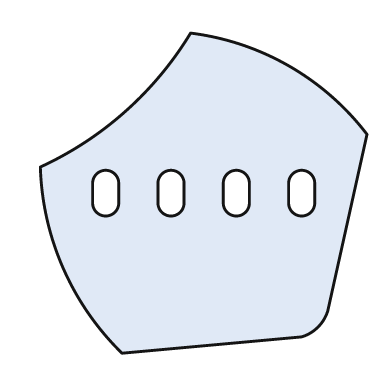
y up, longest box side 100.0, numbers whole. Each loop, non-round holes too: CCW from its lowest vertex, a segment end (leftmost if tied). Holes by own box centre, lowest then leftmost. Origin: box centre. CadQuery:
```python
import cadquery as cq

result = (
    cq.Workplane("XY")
    .moveTo(-25.0, -49.0)
    .lineTo(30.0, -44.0)
    .threePointArc((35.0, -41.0), (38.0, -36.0))
    .lineTo(50.0, 18.0)
    .threePointArc((26.0, 39.0), (-4.0, 49.0))
    .threePointArc((-24.0, 25.0), (-50.0, 8.0))
    .threePointArc((-43.0, -23.0), (-25.0, -49.0))
    .close()
    .moveTo(-34.0, -3.0)
    .threePointArc((-30.0, -7.0), (-26.0, -3.0))
    .lineTo(-26.0, 3.0)
    .threePointArc((-30.0, 7.0), (-34.0, 3.0))
    .close()
    .moveTo(-14.0, -3.0)
    .threePointArc((-10.0, -7.0), (-6.0, -3.0))
    .lineTo(-6.0, 3.0)
    .threePointArc((-10.0, 7.0), (-14.0, 3.0))
    .close()
    .moveTo(6.0, -3.0)
    .threePointArc((10.0, -7.0), (14.0, -3.0))
    .lineTo(14.0, 3.0)
    .threePointArc((10.0, 7.0), (6.0, 3.0))
    .close()
    .moveTo(26.0, -3.0)
    .threePointArc((30.0, -7.0), (34.0, -3.0))
    .lineTo(34.0, 3.0)
    .threePointArc((30.0, 7.0), (26.0, 3.0))
    .close()
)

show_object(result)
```